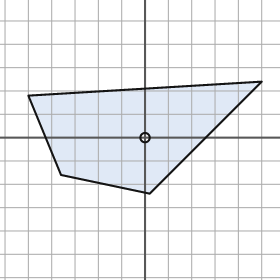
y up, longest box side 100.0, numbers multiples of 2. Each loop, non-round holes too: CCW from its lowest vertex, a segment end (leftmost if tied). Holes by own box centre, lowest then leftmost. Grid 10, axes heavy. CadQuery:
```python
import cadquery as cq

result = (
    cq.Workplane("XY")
    .moveTo(2.0, -24.0)
    .lineTo(50.0, 24.0)
    .lineTo(-50.0, 18.0)
    .lineTo(-36.0, -16.0)
    .close()
    .moveTo(0.0, 0.0)
    .circle(2.0)
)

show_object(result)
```